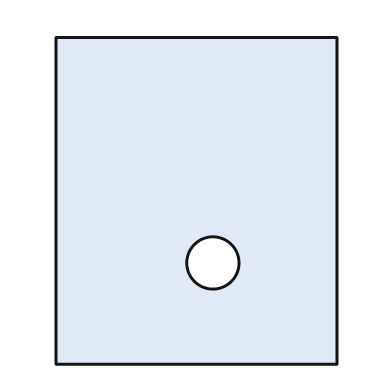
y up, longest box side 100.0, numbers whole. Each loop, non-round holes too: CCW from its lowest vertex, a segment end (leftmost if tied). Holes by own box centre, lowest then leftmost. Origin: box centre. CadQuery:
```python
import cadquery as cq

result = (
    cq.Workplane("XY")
    .moveTo(-43.0, -50.0)
    .lineTo(43.0, -50.0)
    .lineTo(43.0, 50.0)
    .lineTo(-43.0, 50.0)
    .close()
    .moveTo(5.0, -19.0)
    .circle(8.0)
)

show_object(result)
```